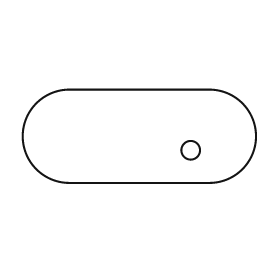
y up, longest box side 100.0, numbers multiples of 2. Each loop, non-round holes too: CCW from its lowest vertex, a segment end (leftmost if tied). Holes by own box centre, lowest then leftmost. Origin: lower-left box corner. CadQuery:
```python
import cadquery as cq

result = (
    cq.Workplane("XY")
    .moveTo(20.0, 0.0)
    .lineTo(80.0, 0.0)
    .threePointArc((100.0, 20.0), (80.0, 40.0))
    .lineTo(20.0, 40.0)
    .threePointArc((0.0, 20.0), (20.0, 0.0))
    .close()
    .moveTo(72.0, 14.0)
    .circle(4.0)
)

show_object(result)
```